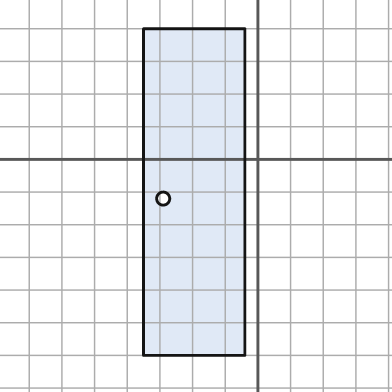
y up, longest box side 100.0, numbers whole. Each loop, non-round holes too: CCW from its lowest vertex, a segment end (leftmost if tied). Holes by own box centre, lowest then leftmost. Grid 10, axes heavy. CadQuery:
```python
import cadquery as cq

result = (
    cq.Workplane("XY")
    .moveTo(-35.0, -60.0)
    .lineTo(-4.0, -60.0)
    .lineTo(-4.0, 40.0)
    .lineTo(-35.0, 40.0)
    .close()
    .moveTo(-29.0, -12.0)
    .circle(2.0)
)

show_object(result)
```